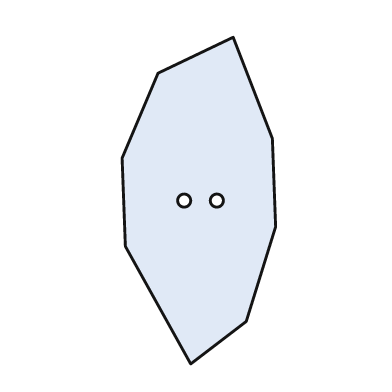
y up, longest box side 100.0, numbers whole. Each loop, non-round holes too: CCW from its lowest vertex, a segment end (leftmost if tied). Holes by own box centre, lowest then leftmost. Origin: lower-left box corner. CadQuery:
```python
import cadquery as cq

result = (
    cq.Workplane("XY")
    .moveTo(21.0, 0.0)
    .lineTo(38.0, 13.0)
    .lineTo(47.0, 42.0)
    .lineTo(46.0, 69.0)
    .lineTo(34.0, 100.0)
    .lineTo(11.0, 89.0)
    .lineTo(0.0, 63.0)
    .lineTo(1.0, 36.0)
    .close()
    .moveTo(19.0, 50.0)
    .circle(2.0)
    .moveTo(29.0, 50.0)
    .circle(2.0)
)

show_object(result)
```